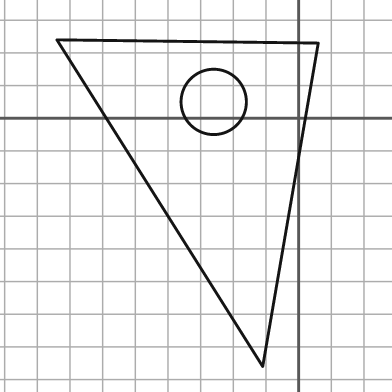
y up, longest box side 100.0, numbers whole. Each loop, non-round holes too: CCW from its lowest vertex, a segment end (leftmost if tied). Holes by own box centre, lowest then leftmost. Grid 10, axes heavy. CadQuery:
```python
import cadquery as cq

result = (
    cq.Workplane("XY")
    .moveTo(-11.0, -76.0)
    .lineTo(6.0, 23.0)
    .lineTo(-74.0, 24.0)
    .close()
    .moveTo(-26.0, 5.0)
    .circle(10.0)
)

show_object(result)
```